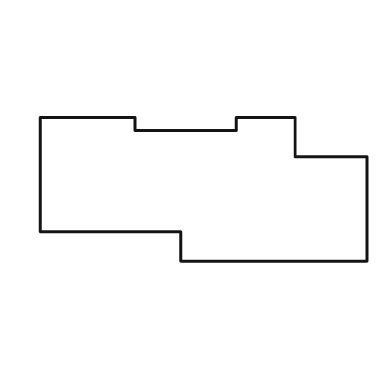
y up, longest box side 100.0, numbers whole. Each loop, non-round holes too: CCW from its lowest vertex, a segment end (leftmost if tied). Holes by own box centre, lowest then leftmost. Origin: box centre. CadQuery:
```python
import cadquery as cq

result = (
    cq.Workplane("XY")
    .moveTo(-7.0, -22.0)
    .lineTo(50.0, -22.0)
    .lineTo(50.0, 10.0)
    .lineTo(28.0, 10.0)
    .lineTo(28.0, 22.0)
    .lineTo(10.0, 22.0)
    .lineTo(10.0, 18.0)
    .lineTo(-21.0, 18.0)
    .lineTo(-21.0, 22.0)
    .lineTo(-50.0, 22.0)
    .lineTo(-50.0, -13.0)
    .lineTo(-7.0, -13.0)
    .close()
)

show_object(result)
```